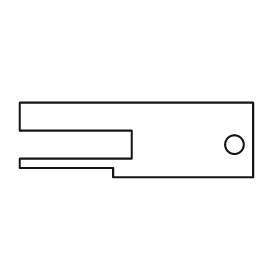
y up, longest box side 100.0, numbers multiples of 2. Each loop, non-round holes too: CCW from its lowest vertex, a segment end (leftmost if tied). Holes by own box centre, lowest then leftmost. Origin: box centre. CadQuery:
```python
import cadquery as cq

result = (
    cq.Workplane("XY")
    .moveTo(-10.0, -16.0)
    .lineTo(50.0, -16.0)
    .lineTo(50.0, 16.0)
    .lineTo(-50.0, 16.0)
    .lineTo(-50.0, 4.0)
    .lineTo(-2.0, 4.0)
    .lineTo(-2.0, -8.0)
    .lineTo(-50.0, -8.0)
    .lineTo(-50.0, -12.0)
    .lineTo(-10.0, -12.0)
    .close()
    .moveTo(42.0, -2.0)
    .circle(4.0)
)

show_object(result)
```